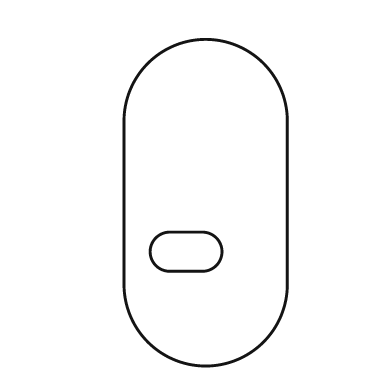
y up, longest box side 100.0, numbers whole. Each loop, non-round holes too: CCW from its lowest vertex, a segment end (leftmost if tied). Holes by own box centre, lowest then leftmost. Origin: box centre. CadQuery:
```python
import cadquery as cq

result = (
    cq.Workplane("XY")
    .moveTo(-25.0, -25.0)
    .threePointArc((0.0, -50.0), (25.0, -25.0))
    .lineTo(25.0, 25.0)
    .threePointArc((0.0, 50.0), (-25.0, 25.0))
    .close()
    .moveTo(-11.0, -21.0)
    .lineTo(-1.0, -21.0)
    .threePointArc((5.0, -15.0), (-1.0, -9.0))
    .lineTo(-11.0, -9.0)
    .threePointArc((-17.0, -15.0), (-11.0, -21.0))
    .close()
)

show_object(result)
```